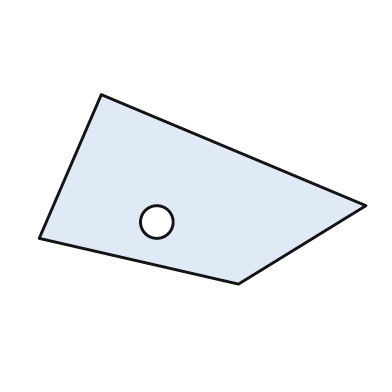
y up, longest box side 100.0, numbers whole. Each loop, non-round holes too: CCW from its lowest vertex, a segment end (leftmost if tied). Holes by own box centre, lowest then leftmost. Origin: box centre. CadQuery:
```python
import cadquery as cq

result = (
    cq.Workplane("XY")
    .moveTo(11.0, -29.0)
    .lineTo(50.0, -5.0)
    .lineTo(-31.0, 29.0)
    .lineTo(-50.0, -15.0)
    .close()
    .moveTo(-14.0, -10.0)
    .circle(5.0)
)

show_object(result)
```